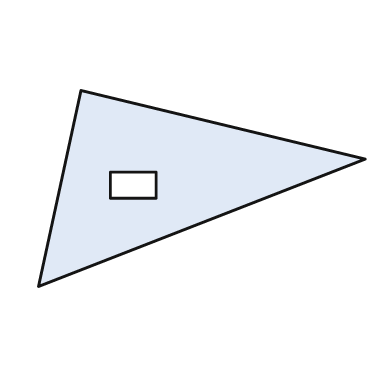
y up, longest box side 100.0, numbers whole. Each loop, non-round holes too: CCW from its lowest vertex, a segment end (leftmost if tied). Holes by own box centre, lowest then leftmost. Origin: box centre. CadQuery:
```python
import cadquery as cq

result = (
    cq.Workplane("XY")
    .moveTo(-50.0, -30.0)
    .lineTo(50.0, 9.0)
    .lineTo(-37.0, 30.0)
    .close()
    .moveTo(-28.0, -3.0)
    .lineTo(-14.0, -3.0)
    .lineTo(-14.0, 5.0)
    .lineTo(-28.0, 5.0)
    .close()
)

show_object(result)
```